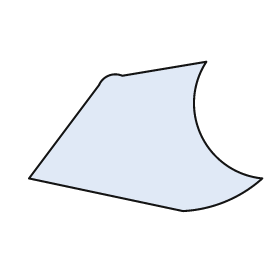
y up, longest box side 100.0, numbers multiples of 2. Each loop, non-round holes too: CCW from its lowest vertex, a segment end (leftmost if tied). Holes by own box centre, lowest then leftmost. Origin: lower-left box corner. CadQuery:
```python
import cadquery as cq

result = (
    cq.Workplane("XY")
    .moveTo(66.0, 0.0)
    .threePointArc((84.0, 4.0), (100.0, 14.0))
    .threePointArc((74.0, 32.0), (76.0, 64.0))
    .lineTo(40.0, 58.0)
    .threePointArc((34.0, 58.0), (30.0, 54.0))
    .lineTo(0.0, 14.0)
    .close()
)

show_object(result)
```